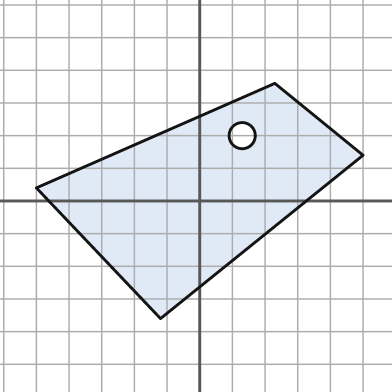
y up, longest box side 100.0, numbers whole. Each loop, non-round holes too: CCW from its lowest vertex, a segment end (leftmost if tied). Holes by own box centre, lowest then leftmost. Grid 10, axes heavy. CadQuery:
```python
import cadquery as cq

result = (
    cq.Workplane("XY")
    .moveTo(-12.0, -36.0)
    .lineTo(50.0, 14.0)
    .lineTo(23.0, 36.0)
    .lineTo(-50.0, 4.0)
    .close()
    .moveTo(13.0, 20.0)
    .circle(4.0)
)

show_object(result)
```